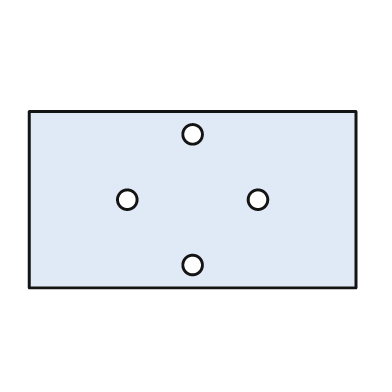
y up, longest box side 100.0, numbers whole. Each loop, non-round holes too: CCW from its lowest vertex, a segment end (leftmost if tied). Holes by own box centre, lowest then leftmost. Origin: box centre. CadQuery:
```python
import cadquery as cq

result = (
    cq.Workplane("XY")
    .moveTo(-50.0, -27.0)
    .lineTo(50.0, -27.0)
    .lineTo(50.0, 27.0)
    .lineTo(-50.0, 27.0)
    .close()
    .moveTo(0.0, -20.0)
    .circle(3.0)
    .moveTo(-20.0, 0.0)
    .circle(3.0)
    .moveTo(20.0, 0.0)
    .circle(3.0)
    .moveTo(0.0, 20.0)
    .circle(3.0)
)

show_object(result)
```